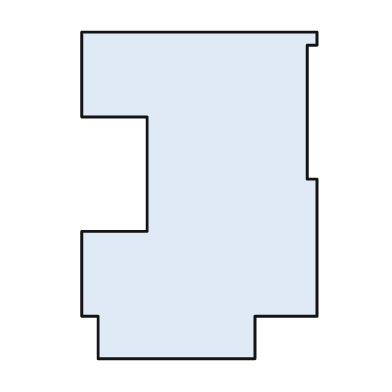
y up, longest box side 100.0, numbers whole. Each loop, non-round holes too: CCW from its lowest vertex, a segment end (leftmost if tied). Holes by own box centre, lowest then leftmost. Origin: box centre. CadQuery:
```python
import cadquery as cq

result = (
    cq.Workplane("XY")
    .moveTo(-31.0, -50.0)
    .lineTo(17.0, -50.0)
    .lineTo(17.0, -37.0)
    .lineTo(36.0, -37.0)
    .lineTo(36.0, 5.0)
    .lineTo(33.0, 5.0)
    .lineTo(33.0, 46.0)
    .lineTo(36.0, 46.0)
    .lineTo(36.0, 50.0)
    .lineTo(-36.0, 50.0)
    .lineTo(-36.0, 24.0)
    .lineTo(-16.0, 24.0)
    .lineTo(-16.0, -11.0)
    .lineTo(-36.0, -11.0)
    .lineTo(-36.0, -37.0)
    .lineTo(-31.0, -37.0)
    .close()
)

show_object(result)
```